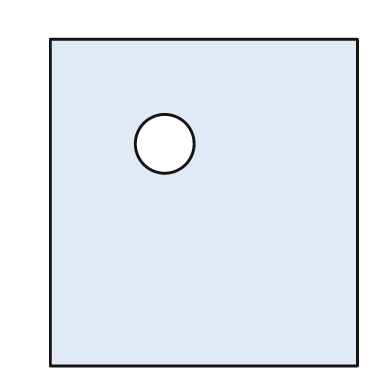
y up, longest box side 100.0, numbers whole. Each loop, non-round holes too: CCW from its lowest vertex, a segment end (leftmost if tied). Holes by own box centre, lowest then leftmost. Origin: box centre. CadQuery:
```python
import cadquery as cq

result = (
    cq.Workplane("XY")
    .moveTo(-47.0, -50.0)
    .lineTo(47.0, -50.0)
    .lineTo(47.0, 50.0)
    .lineTo(-47.0, 50.0)
    .close()
    .moveTo(-12.0, 18.0)
    .circle(9.0)
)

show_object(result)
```